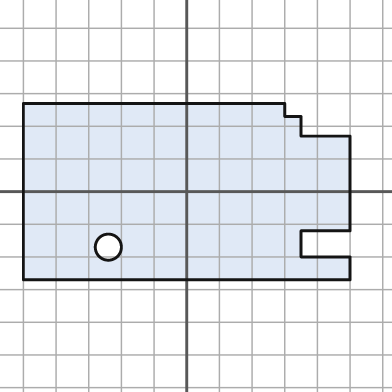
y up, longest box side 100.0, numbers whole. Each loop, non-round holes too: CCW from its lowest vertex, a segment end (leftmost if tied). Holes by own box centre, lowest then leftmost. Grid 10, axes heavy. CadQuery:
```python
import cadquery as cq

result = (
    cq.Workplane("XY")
    .moveTo(-50.0, -27.0)
    .lineTo(50.0, -27.0)
    .lineTo(50.0, -20.0)
    .lineTo(35.0, -20.0)
    .lineTo(35.0, -12.0)
    .lineTo(50.0, -12.0)
    .lineTo(50.0, 17.0)
    .lineTo(35.0, 17.0)
    .lineTo(35.0, 23.0)
    .lineTo(30.0, 23.0)
    .lineTo(30.0, 27.0)
    .lineTo(-50.0, 27.0)
    .close()
    .moveTo(-24.0, -17.0)
    .circle(4.0)
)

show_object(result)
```